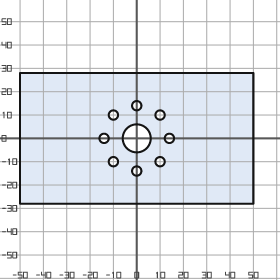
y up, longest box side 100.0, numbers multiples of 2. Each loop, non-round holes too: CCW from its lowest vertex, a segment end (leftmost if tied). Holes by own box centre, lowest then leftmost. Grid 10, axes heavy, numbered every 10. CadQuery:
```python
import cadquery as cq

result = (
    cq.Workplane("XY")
    .moveTo(-50.0, -28.0)
    .lineTo(50.0, -28.0)
    .lineTo(50.0, 28.0)
    .lineTo(-50.0, 28.0)
    .close()
    .moveTo(0.0, -14.0)
    .circle(2.0)
    .moveTo(-10.0, -10.0)
    .circle(2.0)
    .moveTo(10.0, -10.0)
    .circle(2.0)
    .moveTo(-14.0, 0.0)
    .circle(2.0)
    .moveTo(0.0, 0.0)
    .circle(6.0)
    .moveTo(14.0, 0.0)
    .circle(2.0)
    .moveTo(-10.0, 10.0)
    .circle(2.0)
    .moveTo(10.0, 10.0)
    .circle(2.0)
    .moveTo(0.0, 14.0)
    .circle(2.0)
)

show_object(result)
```